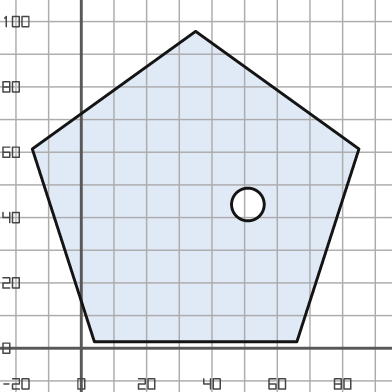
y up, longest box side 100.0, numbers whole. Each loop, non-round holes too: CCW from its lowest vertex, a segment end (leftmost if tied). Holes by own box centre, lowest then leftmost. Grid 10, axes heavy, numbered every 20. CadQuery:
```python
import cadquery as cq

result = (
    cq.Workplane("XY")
    .moveTo(4.0, 2.0)
    .lineTo(66.0, 2.0)
    .lineTo(85.0, 61.0)
    .lineTo(35.0, 97.0)
    .lineTo(-15.0, 61.0)
    .close()
    .moveTo(51.0, 44.0)
    .circle(5.0)
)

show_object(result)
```